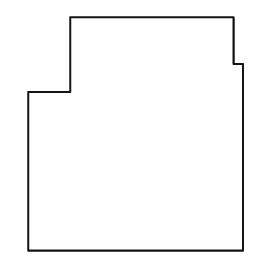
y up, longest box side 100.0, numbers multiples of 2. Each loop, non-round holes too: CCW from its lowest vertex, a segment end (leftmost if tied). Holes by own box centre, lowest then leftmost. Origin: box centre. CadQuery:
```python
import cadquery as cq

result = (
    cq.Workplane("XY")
    .moveTo(-46.0, -50.0)
    .lineTo(46.0, -50.0)
    .lineTo(46.0, 30.0)
    .lineTo(42.0, 30.0)
    .lineTo(42.0, 50.0)
    .lineTo(-28.0, 50.0)
    .lineTo(-28.0, 18.0)
    .lineTo(-46.0, 18.0)
    .close()
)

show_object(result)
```